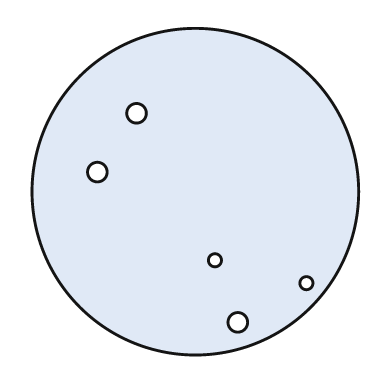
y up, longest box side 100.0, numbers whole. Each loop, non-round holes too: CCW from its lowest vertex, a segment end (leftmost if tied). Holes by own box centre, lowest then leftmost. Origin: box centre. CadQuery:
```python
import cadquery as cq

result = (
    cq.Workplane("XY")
    .moveTo(0.0, 0.0)
    .circle(50.0)
    .moveTo(13.0, -40.0)
    .circle(3.0)
    .moveTo(34.0, -28.0)
    .circle(2.0)
    .moveTo(6.0, -21.0)
    .circle(2.0)
    .moveTo(-30.0, 6.0)
    .circle(3.0)
    .moveTo(-18.0, 24.0)
    .circle(3.0)
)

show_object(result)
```